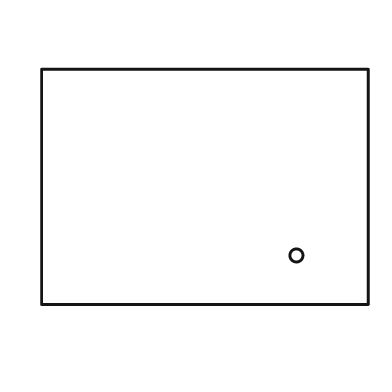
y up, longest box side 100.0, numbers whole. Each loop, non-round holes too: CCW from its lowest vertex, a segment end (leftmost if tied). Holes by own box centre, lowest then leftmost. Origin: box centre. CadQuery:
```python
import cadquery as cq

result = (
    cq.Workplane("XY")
    .moveTo(-50.0, -36.0)
    .lineTo(50.0, -36.0)
    .lineTo(50.0, 36.0)
    .lineTo(-50.0, 36.0)
    .close()
    .moveTo(28.0, -21.0)
    .circle(2.0)
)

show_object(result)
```